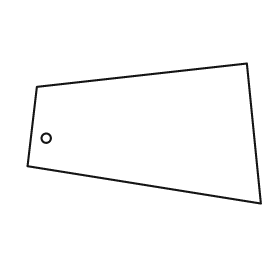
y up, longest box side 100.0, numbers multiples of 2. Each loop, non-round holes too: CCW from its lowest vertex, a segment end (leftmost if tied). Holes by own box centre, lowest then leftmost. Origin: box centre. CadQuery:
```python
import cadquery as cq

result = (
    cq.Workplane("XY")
    .moveTo(50.0, -30.0)
    .lineTo(44.0, 30.0)
    .lineTo(-46.0, 20.0)
    .lineTo(-50.0, -14.0)
    .close()
    .moveTo(-42.0, -2.0)
    .circle(2.0)
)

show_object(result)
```